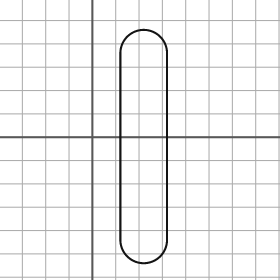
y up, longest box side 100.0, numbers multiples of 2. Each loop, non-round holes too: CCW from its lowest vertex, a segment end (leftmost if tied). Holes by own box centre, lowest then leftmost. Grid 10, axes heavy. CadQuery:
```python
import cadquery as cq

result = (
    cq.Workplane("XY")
    .moveTo(12.0, -44.0)
    .threePointArc((22.0, -54.0), (32.0, -44.0))
    .lineTo(32.0, 36.0)
    .threePointArc((22.0, 46.0), (12.0, 36.0))
    .close()
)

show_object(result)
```